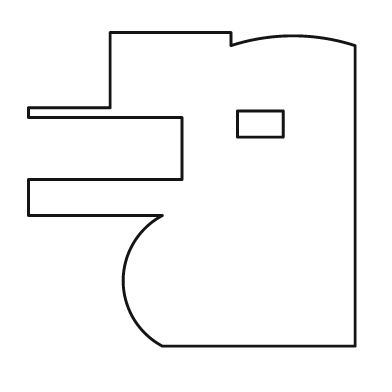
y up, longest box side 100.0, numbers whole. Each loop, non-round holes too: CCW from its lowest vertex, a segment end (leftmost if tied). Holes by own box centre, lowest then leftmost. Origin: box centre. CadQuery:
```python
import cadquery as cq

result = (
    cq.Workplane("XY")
    .moveTo(-9.0, -48.0)
    .lineTo(50.0, -48.0)
    .lineTo(50.0, 44.0)
    .threePointArc((31.0, 47.0), (12.0, 44.0))
    .lineTo(12.0, 48.0)
    .lineTo(-25.0, 48.0)
    .lineTo(-25.0, 25.0)
    .lineTo(-50.0, 25.0)
    .lineTo(-50.0, 22.0)
    .lineTo(-3.0, 22.0)
    .lineTo(-3.0, 3.0)
    .lineTo(-50.0, 3.0)
    .lineTo(-50.0, -8.0)
    .lineTo(-9.0, -8.0)
    .threePointArc((-21.0, -28.0), (-9.0, -48.0))
    .close()
    .moveTo(14.0, 16.0)
    .lineTo(28.0, 16.0)
    .lineTo(28.0, 24.0)
    .lineTo(14.0, 24.0)
    .close()
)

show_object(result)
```